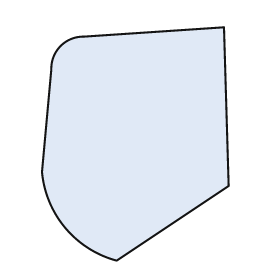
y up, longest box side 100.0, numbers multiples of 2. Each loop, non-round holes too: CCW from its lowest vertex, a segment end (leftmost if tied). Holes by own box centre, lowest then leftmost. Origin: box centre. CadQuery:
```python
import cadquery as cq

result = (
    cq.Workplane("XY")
    .moveTo(-8.0, -50.0)
    .lineTo(40.0, -18.0)
    .lineTo(38.0, 50.0)
    .lineTo(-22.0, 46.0)
    .threePointArc((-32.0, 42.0), (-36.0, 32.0))
    .lineTo(-40.0, -12.0)
    .threePointArc((-30.0, -36.0), (-8.0, -50.0))
    .close()
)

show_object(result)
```